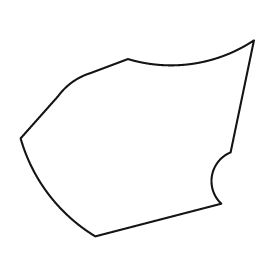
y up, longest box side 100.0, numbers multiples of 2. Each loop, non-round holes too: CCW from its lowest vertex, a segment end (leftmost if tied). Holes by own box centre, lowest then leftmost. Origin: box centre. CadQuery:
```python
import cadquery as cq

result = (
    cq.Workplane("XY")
    .moveTo(-18.0, -42.0)
    .lineTo(36.0, -28.0)
    .threePointArc((32.0, -16.0), (40.0, -6.0))
    .lineTo(50.0, 42.0)
    .threePointArc((24.0, 32.0), (-4.0, 34.0))
    .lineTo(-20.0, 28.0)
    .threePointArc((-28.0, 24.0), (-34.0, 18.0))
    .lineTo(-50.0, 0.0)
    .threePointArc((-38.0, -24.0), (-18.0, -42.0))
    .close()
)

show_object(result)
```